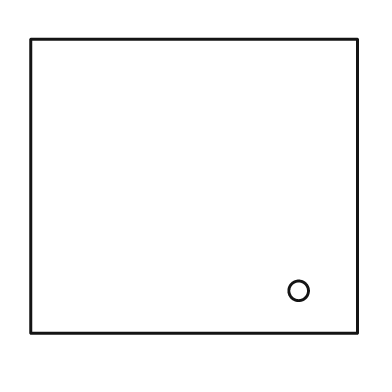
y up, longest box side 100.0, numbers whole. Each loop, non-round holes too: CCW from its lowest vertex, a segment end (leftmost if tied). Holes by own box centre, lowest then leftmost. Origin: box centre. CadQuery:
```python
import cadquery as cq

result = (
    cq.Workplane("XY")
    .moveTo(-50.0, -45.0)
    .lineTo(50.0, -45.0)
    .lineTo(50.0, 45.0)
    .lineTo(-50.0, 45.0)
    .close()
    .moveTo(32.0, -32.0)
    .circle(3.0)
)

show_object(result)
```